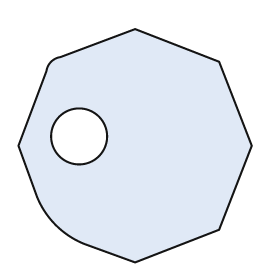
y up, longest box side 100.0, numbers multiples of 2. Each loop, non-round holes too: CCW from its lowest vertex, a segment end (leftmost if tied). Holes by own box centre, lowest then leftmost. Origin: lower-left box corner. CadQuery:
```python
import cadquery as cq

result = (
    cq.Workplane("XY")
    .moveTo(50.0, 0.0)
    .lineTo(86.0, 14.0)
    .lineTo(100.0, 50.0)
    .lineTo(86.0, 86.0)
    .lineTo(50.0, 100.0)
    .lineTo(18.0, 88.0)
    .threePointArc((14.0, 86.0), (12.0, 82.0))
    .lineTo(0.0, 50.0)
    .lineTo(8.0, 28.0)
    .threePointArc((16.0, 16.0), (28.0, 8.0))
    .close()
    .moveTo(26.0, 54.0)
    .circle(12.0)
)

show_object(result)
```